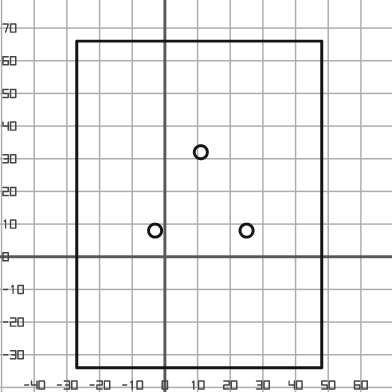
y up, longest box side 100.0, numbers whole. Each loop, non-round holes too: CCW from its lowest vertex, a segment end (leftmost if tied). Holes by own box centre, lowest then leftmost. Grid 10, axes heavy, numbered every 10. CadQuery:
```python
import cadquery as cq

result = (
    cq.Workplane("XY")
    .moveTo(-27.0, -34.0)
    .lineTo(48.0, -34.0)
    .lineTo(48.0, 66.0)
    .lineTo(-27.0, 66.0)
    .close()
    .moveTo(-3.0, 8.0)
    .circle(2.0)
    .moveTo(25.0, 8.0)
    .circle(2.0)
    .moveTo(11.0, 32.0)
    .circle(2.0)
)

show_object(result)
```